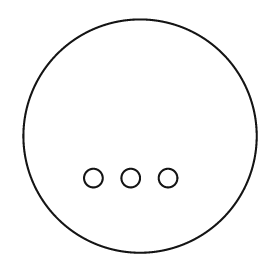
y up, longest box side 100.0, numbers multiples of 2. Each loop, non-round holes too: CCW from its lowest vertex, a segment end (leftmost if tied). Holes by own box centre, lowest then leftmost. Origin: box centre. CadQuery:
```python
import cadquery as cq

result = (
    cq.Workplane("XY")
    .moveTo(0.0, 0.0)
    .circle(50.0)
    .moveTo(-20.0, -18.0)
    .circle(4.0)
    .moveTo(-4.0, -18.0)
    .circle(4.0)
    .moveTo(12.0, -18.0)
    .circle(4.0)
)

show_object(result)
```